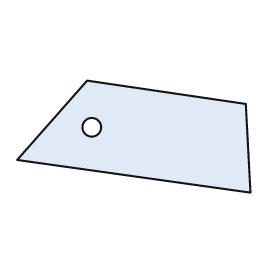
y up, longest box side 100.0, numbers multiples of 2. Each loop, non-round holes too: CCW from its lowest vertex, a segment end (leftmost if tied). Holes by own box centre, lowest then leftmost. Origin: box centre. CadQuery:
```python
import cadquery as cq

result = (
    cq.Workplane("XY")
    .moveTo(50.0, -24.0)
    .lineTo(48.0, 14.0)
    .lineTo(-20.0, 24.0)
    .lineTo(-50.0, -10.0)
    .close()
    .moveTo(-18.0, 4.0)
    .circle(4.0)
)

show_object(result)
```